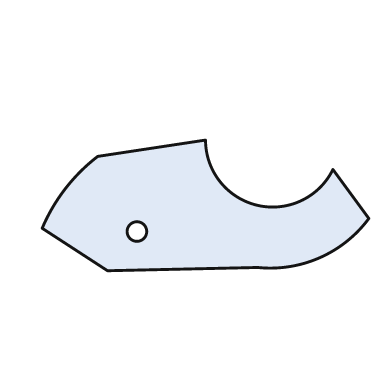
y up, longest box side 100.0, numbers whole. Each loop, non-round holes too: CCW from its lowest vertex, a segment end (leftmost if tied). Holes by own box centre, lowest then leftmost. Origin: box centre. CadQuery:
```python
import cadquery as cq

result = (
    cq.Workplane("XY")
    .moveTo(-30.0, -20.0)
    .lineTo(16.0, -19.0)
    .threePointArc((35.0, -16.0), (50.0, -4.0))
    .lineTo(39.0, 11.0)
    .threePointArc((16.0, 0.0), (0.0, 20.0))
    .lineTo(-33.0, 15.0)
    .threePointArc((-43.0, 5.0), (-50.0, -7.0))
    .close()
    .moveTo(-21.0, -8.0)
    .circle(3.0)
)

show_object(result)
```